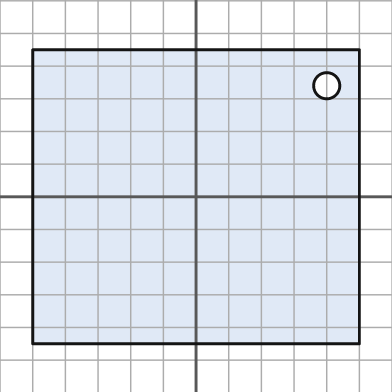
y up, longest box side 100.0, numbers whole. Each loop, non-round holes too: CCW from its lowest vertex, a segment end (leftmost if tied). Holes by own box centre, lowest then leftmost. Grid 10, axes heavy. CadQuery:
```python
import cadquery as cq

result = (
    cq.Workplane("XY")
    .moveTo(-50.0, -45.0)
    .lineTo(50.0, -45.0)
    .lineTo(50.0, 45.0)
    .lineTo(-50.0, 45.0)
    .close()
    .moveTo(40.0, 34.0)
    .circle(4.0)
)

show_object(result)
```